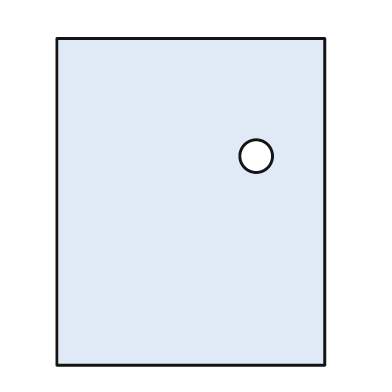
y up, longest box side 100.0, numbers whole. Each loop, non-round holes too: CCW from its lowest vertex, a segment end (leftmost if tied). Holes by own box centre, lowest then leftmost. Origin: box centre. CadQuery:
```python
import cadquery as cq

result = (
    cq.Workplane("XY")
    .moveTo(-41.0, -50.0)
    .lineTo(41.0, -50.0)
    .lineTo(41.0, 50.0)
    .lineTo(-41.0, 50.0)
    .close()
    .moveTo(20.0, 14.0)
    .circle(5.0)
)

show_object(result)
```